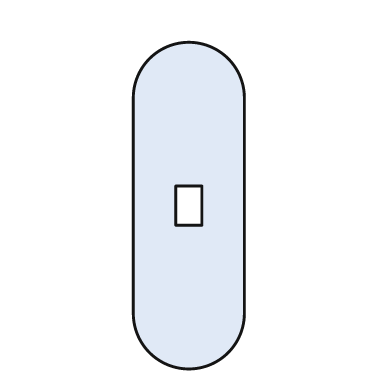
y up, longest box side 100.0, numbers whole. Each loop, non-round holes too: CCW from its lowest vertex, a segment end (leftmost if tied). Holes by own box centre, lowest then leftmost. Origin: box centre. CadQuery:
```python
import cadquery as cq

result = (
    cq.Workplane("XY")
    .moveTo(-17.0, -33.0)
    .threePointArc((0.0, -50.0), (17.0, -33.0))
    .lineTo(17.0, 33.0)
    .threePointArc((0.0, 50.0), (-17.0, 33.0))
    .close()
    .moveTo(-4.0, -6.0)
    .lineTo(4.0, -6.0)
    .lineTo(4.0, 6.0)
    .lineTo(-4.0, 6.0)
    .close()
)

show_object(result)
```